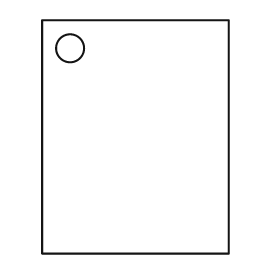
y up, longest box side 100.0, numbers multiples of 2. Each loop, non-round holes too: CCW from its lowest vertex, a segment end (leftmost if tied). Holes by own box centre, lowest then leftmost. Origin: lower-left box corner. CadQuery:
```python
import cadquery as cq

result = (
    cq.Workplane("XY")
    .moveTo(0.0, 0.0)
    .lineTo(80.0, 0.0)
    .lineTo(80.0, 100.0)
    .lineTo(0.0, 100.0)
    .close()
    .moveTo(12.0, 88.0)
    .circle(6.0)
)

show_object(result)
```